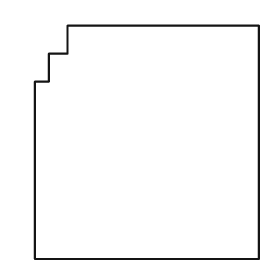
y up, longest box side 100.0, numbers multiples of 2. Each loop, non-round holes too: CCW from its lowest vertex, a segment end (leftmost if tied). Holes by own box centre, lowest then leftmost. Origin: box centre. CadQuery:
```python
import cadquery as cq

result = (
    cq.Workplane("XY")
    .moveTo(-48.0, -50.0)
    .lineTo(48.0, -50.0)
    .lineTo(48.0, 50.0)
    .lineTo(-34.0, 50.0)
    .lineTo(-34.0, 38.0)
    .lineTo(-42.0, 38.0)
    .lineTo(-42.0, 26.0)
    .lineTo(-48.0, 26.0)
    .close()
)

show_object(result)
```